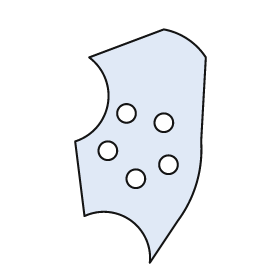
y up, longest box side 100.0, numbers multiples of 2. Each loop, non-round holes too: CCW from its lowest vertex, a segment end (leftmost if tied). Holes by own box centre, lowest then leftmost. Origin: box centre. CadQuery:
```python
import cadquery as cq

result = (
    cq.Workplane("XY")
    .moveTo(4.0, -50.0)
    .lineTo(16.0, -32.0)
    .threePointArc((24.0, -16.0), (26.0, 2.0))
    .lineTo(28.0, 38.0)
    .threePointArc((20.0, 46.0), (10.0, 50.0))
    .lineTo(-22.0, 38.0)
    .threePointArc((-14.0, 18.0), (-28.0, 2.0))
    .lineTo(-24.0, -30.0)
    .threePointArc((-4.0, -32.0), (4.0, -50.0))
    .close()
    .moveTo(-2.0, -14.0)
    .circle(4.0)
    .moveTo(12.0, -8.0)
    .circle(4.0)
    .moveTo(-14.0, -2.0)
    .circle(4.0)
    .moveTo(10.0, 10.0)
    .circle(4.0)
    .moveTo(-6.0, 14.0)
    .circle(4.0)
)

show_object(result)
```